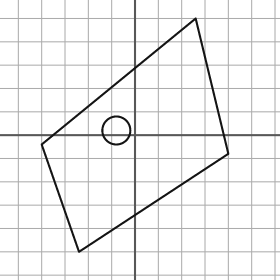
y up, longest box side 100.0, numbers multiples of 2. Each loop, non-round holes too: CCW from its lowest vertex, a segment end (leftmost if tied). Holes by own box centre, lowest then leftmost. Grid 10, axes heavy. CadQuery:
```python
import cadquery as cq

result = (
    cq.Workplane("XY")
    .moveTo(-24.0, -50.0)
    .lineTo(40.0, -8.0)
    .lineTo(26.0, 50.0)
    .lineTo(-40.0, -4.0)
    .close()
    .moveTo(-8.0, 2.0)
    .circle(6.0)
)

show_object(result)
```